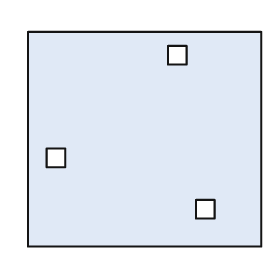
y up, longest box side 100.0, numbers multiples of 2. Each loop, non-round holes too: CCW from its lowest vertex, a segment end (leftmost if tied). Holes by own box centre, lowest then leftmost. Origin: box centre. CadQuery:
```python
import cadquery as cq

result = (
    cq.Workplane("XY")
    .moveTo(-50.0, -46.0)
    .lineTo(50.0, -46.0)
    .lineTo(50.0, 46.0)
    .lineTo(-50.0, 46.0)
    .close()
    .moveTo(22.0, -34.0)
    .lineTo(30.0, -34.0)
    .lineTo(30.0, -26.0)
    .lineTo(22.0, -26.0)
    .close()
    .moveTo(-42.0, -12.0)
    .lineTo(-34.0, -12.0)
    .lineTo(-34.0, -4.0)
    .lineTo(-42.0, -4.0)
    .close()
    .moveTo(10.0, 32.0)
    .lineTo(18.0, 32.0)
    .lineTo(18.0, 40.0)
    .lineTo(10.0, 40.0)
    .close()
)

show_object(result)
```